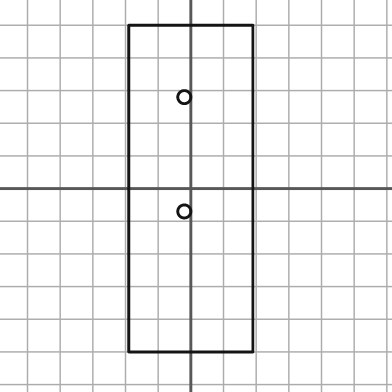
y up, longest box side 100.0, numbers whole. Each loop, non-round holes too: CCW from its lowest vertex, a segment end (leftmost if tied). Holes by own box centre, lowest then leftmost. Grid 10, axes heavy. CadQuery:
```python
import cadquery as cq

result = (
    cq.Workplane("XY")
    .moveTo(-19.0, -50.0)
    .lineTo(19.0, -50.0)
    .lineTo(19.0, 50.0)
    .lineTo(-19.0, 50.0)
    .close()
    .moveTo(-2.0, -7.0)
    .circle(2.0)
    .moveTo(-2.0, 28.0)
    .circle(2.0)
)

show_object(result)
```